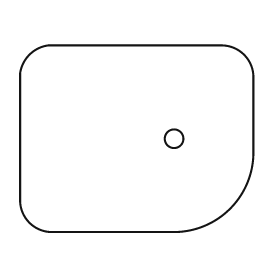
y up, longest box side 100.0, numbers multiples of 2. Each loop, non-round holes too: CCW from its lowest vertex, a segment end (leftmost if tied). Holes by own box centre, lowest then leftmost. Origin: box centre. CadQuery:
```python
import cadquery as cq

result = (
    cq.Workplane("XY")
    .moveTo(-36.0, -40.0)
    .lineTo(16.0, -40.0)
    .threePointArc((40.0, -30.0), (50.0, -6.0))
    .lineTo(50.0, 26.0)
    .threePointArc((46.0, 36.0), (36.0, 40.0))
    .lineTo(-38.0, 40.0)
    .threePointArc((-46.0, 36.0), (-50.0, 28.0))
    .lineTo(-50.0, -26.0)
    .threePointArc((-46.0, -36.0), (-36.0, -40.0))
    .close()
    .moveTo(16.0, 0.0)
    .circle(4.0)
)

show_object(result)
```